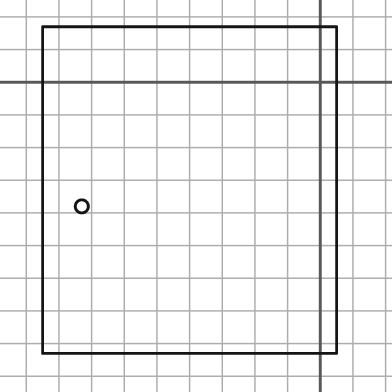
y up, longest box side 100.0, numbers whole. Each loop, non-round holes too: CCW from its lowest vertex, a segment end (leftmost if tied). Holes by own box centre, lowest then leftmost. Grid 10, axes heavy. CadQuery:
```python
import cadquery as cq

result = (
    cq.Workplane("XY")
    .moveTo(-85.0, -83.0)
    .lineTo(5.0, -83.0)
    .lineTo(5.0, 17.0)
    .lineTo(-85.0, 17.0)
    .close()
    .moveTo(-73.0, -38.0)
    .circle(2.0)
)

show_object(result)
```